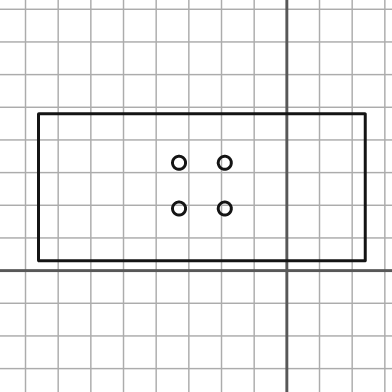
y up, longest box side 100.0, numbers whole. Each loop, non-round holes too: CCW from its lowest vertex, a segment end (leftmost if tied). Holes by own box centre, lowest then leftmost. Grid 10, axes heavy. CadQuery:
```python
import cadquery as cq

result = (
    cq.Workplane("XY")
    .moveTo(-76.0, 3.0)
    .lineTo(24.0, 3.0)
    .lineTo(24.0, 48.0)
    .lineTo(-76.0, 48.0)
    .close()
    .moveTo(-33.0, 19.0)
    .circle(2.0)
    .moveTo(-19.0, 19.0)
    .circle(2.0)
    .moveTo(-33.0, 33.0)
    .circle(2.0)
    .moveTo(-19.0, 33.0)
    .circle(2.0)
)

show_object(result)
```